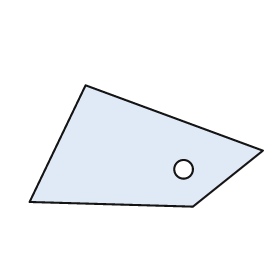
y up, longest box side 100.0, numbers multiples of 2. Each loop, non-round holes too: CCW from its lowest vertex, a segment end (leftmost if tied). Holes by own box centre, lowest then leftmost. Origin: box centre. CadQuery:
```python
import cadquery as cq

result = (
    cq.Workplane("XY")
    .moveTo(20.0, -26.0)
    .lineTo(50.0, -2.0)
    .lineTo(-26.0, 26.0)
    .lineTo(-50.0, -24.0)
    .close()
    .moveTo(16.0, -10.0)
    .circle(4.0)
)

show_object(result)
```